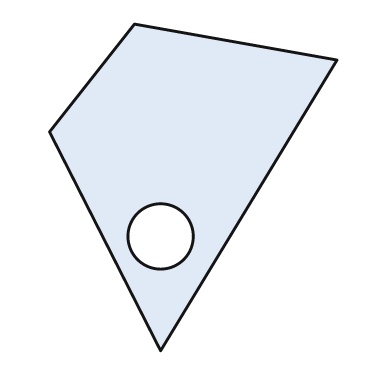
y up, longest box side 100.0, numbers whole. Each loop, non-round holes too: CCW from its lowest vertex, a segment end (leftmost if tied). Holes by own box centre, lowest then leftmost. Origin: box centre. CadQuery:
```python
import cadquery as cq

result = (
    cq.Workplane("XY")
    .moveTo(-10.0, -50.0)
    .lineTo(44.0, 39.0)
    .lineTo(-18.0, 50.0)
    .lineTo(-44.0, 17.0)
    .close()
    .moveTo(-10.0, -15.0)
    .circle(10.0)
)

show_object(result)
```